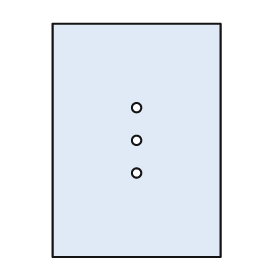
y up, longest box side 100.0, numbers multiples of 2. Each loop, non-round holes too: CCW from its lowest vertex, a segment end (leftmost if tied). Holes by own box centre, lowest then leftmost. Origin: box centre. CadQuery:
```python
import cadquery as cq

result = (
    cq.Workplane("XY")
    .moveTo(-36.0, -50.0)
    .lineTo(36.0, -50.0)
    .lineTo(36.0, 50.0)
    .lineTo(-36.0, 50.0)
    .close()
    .moveTo(0.0, -14.0)
    .circle(2.0)
    .moveTo(0.0, 0.0)
    .circle(2.0)
    .moveTo(0.0, 14.0)
    .circle(2.0)
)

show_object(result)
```